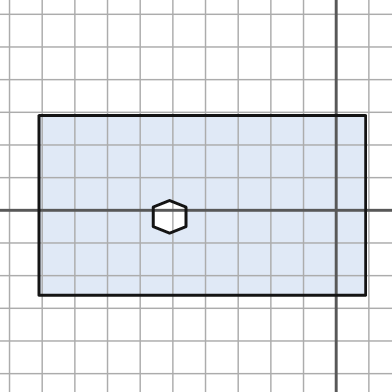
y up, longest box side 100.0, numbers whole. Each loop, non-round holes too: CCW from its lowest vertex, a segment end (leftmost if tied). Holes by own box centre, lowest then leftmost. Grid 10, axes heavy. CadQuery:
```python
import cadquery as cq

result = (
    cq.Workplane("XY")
    .moveTo(-91.0, -26.0)
    .lineTo(9.0, -26.0)
    .lineTo(9.0, 29.0)
    .lineTo(-91.0, 29.0)
    .close()
    .moveTo(-51.0, -7.0)
    .lineTo(-46.0, -5.0)
    .lineTo(-46.0, 1.0)
    .lineTo(-51.0, 3.0)
    .lineTo(-56.0, 1.0)
    .lineTo(-56.0, -5.0)
    .close()
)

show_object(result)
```